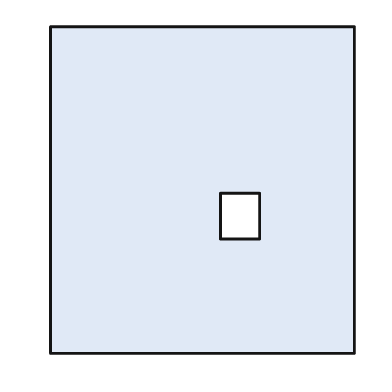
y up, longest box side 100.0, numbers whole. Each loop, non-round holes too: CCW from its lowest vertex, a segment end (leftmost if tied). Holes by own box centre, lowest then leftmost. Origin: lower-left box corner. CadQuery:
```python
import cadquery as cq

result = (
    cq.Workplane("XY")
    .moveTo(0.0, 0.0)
    .lineTo(93.0, 0.0)
    .lineTo(93.0, 100.0)
    .lineTo(0.0, 100.0)
    .close()
    .moveTo(52.0, 35.0)
    .lineTo(64.0, 35.0)
    .lineTo(64.0, 49.0)
    .lineTo(52.0, 49.0)
    .close()
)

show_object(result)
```